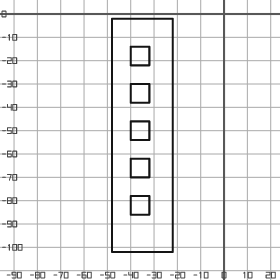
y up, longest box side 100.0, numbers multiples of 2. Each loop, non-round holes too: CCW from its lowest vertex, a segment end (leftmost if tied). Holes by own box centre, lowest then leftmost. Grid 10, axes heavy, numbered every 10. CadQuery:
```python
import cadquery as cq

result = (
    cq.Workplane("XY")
    .moveTo(-48.0, -102.0)
    .lineTo(-22.0, -102.0)
    .lineTo(-22.0, -2.0)
    .lineTo(-48.0, -2.0)
    .close()
    .moveTo(-40.0, -86.0)
    .lineTo(-32.0, -86.0)
    .lineTo(-32.0, -78.0)
    .lineTo(-40.0, -78.0)
    .close()
    .moveTo(-40.0, -70.0)
    .lineTo(-32.0, -70.0)
    .lineTo(-32.0, -62.0)
    .lineTo(-40.0, -62.0)
    .close()
    .moveTo(-40.0, -54.0)
    .lineTo(-32.0, -54.0)
    .lineTo(-32.0, -46.0)
    .lineTo(-40.0, -46.0)
    .close()
    .moveTo(-40.0, -38.0)
    .lineTo(-32.0, -38.0)
    .lineTo(-32.0, -30.0)
    .lineTo(-40.0, -30.0)
    .close()
    .moveTo(-40.0, -22.0)
    .lineTo(-32.0, -22.0)
    .lineTo(-32.0, -14.0)
    .lineTo(-40.0, -14.0)
    .close()
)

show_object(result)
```